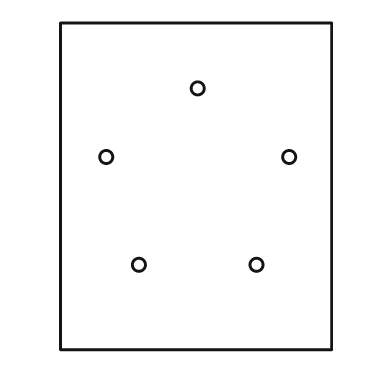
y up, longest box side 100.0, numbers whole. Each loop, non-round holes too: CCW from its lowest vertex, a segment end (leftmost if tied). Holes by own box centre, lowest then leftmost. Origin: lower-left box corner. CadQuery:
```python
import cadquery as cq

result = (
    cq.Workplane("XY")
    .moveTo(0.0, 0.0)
    .lineTo(83.0, 0.0)
    .lineTo(83.0, 100.0)
    .lineTo(0.0, 100.0)
    .close()
    .moveTo(24.0, 26.0)
    .circle(2.0)
    .moveTo(60.0, 26.0)
    .circle(2.0)
    .moveTo(14.0, 59.0)
    .circle(2.0)
    .moveTo(70.0, 59.0)
    .circle(2.0)
    .moveTo(42.0, 80.0)
    .circle(2.0)
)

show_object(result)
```